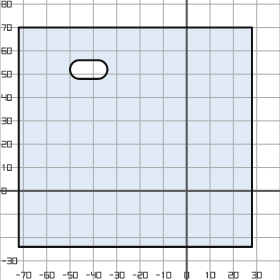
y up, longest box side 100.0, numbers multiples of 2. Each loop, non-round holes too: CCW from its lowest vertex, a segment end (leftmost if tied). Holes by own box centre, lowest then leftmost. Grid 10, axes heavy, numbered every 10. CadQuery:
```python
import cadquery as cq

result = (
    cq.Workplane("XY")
    .moveTo(-72.0, -24.0)
    .lineTo(28.0, -24.0)
    .lineTo(28.0, 70.0)
    .lineTo(-72.0, 70.0)
    .close()
    .moveTo(-46.0, 48.0)
    .lineTo(-38.0, 48.0)
    .threePointArc((-34.0, 52.0), (-38.0, 56.0))
    .lineTo(-46.0, 56.0)
    .threePointArc((-50.0, 52.0), (-46.0, 48.0))
    .close()
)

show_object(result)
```